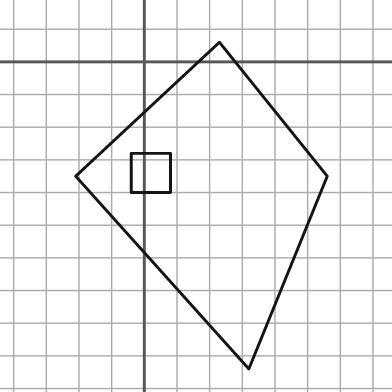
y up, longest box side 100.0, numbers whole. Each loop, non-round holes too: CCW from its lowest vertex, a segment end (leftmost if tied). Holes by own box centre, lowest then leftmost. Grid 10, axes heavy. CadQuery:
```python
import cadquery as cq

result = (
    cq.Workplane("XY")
    .moveTo(32.0, -94.0)
    .lineTo(56.0, -35.0)
    .lineTo(23.0, 6.0)
    .lineTo(-21.0, -35.0)
    .close()
    .moveTo(-4.0, -40.0)
    .lineTo(8.0, -40.0)
    .lineTo(8.0, -28.0)
    .lineTo(-4.0, -28.0)
    .close()
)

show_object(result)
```